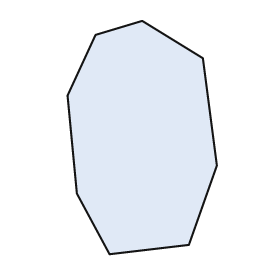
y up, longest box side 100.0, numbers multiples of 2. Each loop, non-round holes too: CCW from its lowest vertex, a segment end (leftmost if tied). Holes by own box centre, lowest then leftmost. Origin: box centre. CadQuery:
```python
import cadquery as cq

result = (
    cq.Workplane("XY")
    .moveTo(-14.0, -50.0)
    .lineTo(20.0, -46.0)
    .lineTo(32.0, -12.0)
    .lineTo(26.0, 34.0)
    .lineTo(0.0, 50.0)
    .lineTo(-20.0, 44.0)
    .lineTo(-32.0, 18.0)
    .lineTo(-28.0, -24.0)
    .close()
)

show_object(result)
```